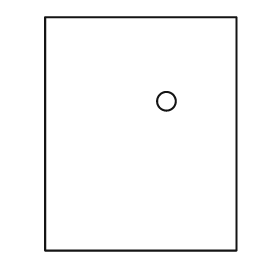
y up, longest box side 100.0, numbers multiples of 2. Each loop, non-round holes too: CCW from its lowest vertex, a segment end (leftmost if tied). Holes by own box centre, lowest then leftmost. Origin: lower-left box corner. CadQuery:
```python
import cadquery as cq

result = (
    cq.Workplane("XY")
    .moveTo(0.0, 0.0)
    .lineTo(82.0, 0.0)
    .lineTo(82.0, 100.0)
    .lineTo(0.0, 100.0)
    .close()
    .moveTo(52.0, 64.0)
    .circle(4.0)
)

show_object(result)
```